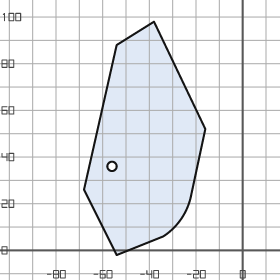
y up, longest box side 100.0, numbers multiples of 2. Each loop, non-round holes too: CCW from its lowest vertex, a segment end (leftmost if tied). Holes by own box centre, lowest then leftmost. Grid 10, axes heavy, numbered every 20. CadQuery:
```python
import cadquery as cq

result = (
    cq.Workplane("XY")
    .moveTo(-54.0, -2.0)
    .lineTo(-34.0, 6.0)
    .threePointArc((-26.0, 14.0), (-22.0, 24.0))
    .lineTo(-16.0, 52.0)
    .lineTo(-38.0, 98.0)
    .lineTo(-54.0, 88.0)
    .lineTo(-68.0, 26.0)
    .close()
    .moveTo(-56.0, 36.0)
    .circle(2.0)
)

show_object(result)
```